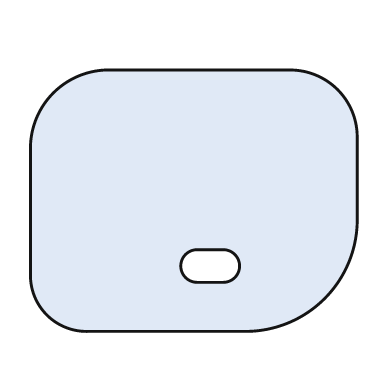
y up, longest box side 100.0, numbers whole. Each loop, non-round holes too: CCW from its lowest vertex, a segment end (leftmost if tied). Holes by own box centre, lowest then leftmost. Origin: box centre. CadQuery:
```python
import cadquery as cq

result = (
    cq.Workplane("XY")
    .moveTo(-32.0, -40.0)
    .lineTo(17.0, -40.0)
    .threePointArc((40.0, -30.0), (50.0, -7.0))
    .lineTo(50.0, 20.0)
    .threePointArc((44.0, 34.0), (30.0, 40.0))
    .lineTo(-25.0, 40.0)
    .threePointArc((-43.0, 33.0), (-50.0, 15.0))
    .lineTo(-50.0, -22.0)
    .threePointArc((-45.0, -35.0), (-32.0, -40.0))
    .close()
    .moveTo(1.0, -25.0)
    .lineTo(9.0, -25.0)
    .threePointArc((14.0, -20.0), (9.0, -15.0))
    .lineTo(1.0, -15.0)
    .threePointArc((-4.0, -20.0), (1.0, -25.0))
    .close()
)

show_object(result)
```